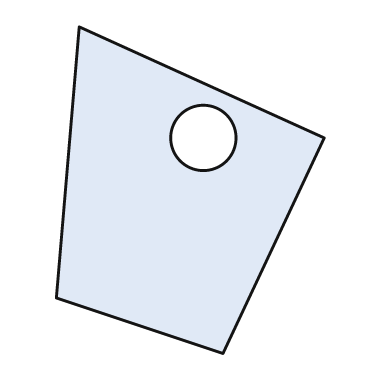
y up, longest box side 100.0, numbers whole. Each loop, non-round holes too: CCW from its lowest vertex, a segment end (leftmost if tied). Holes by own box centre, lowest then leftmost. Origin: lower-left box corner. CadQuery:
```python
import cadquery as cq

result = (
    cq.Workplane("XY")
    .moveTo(51.0, 0.0)
    .lineTo(82.0, 66.0)
    .lineTo(7.0, 100.0)
    .lineTo(0.0, 17.0)
    .close()
    .moveTo(45.0, 66.0)
    .circle(10.0)
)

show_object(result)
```